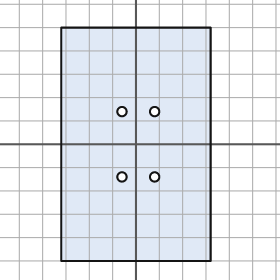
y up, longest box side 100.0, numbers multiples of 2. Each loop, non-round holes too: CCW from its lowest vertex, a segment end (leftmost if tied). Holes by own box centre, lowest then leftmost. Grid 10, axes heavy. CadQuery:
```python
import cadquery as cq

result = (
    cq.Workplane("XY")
    .moveTo(-32.0, -50.0)
    .lineTo(32.0, -50.0)
    .lineTo(32.0, 50.0)
    .lineTo(-32.0, 50.0)
    .close()
    .moveTo(-6.0, -14.0)
    .circle(2.0)
    .moveTo(8.0, -14.0)
    .circle(2.0)
    .moveTo(-6.0, 14.0)
    .circle(2.0)
    .moveTo(8.0, 14.0)
    .circle(2.0)
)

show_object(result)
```